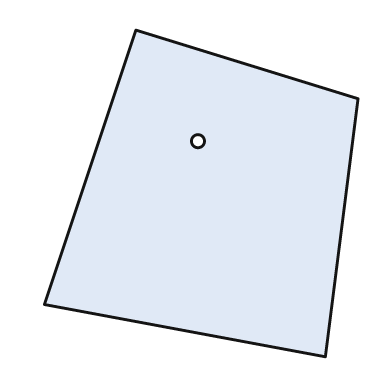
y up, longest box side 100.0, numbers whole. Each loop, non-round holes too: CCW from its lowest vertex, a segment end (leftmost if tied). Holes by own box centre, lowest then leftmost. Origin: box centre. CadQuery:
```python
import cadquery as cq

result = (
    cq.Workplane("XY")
    .moveTo(38.0, -50.0)
    .lineTo(48.0, 29.0)
    .lineTo(-20.0, 50.0)
    .lineTo(-48.0, -34.0)
    .close()
    .moveTo(-1.0, 16.0)
    .circle(2.0)
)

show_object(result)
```